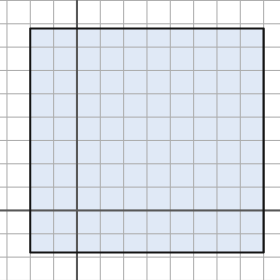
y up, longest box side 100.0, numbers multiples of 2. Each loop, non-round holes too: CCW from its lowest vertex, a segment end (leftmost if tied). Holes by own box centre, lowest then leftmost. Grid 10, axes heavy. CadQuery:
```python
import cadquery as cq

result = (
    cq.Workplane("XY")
    .moveTo(-20.0, -18.0)
    .lineTo(80.0, -18.0)
    .lineTo(80.0, 78.0)
    .lineTo(-20.0, 78.0)
    .close()
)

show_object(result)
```